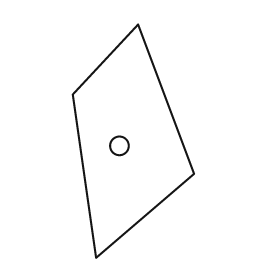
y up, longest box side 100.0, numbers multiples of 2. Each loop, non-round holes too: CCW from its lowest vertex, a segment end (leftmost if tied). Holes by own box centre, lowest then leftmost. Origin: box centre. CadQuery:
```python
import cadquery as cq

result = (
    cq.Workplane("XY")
    .moveTo(-16.0, -50.0)
    .lineTo(26.0, -14.0)
    .lineTo(2.0, 50.0)
    .lineTo(-26.0, 20.0)
    .close()
    .moveTo(-6.0, -2.0)
    .circle(4.0)
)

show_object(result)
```